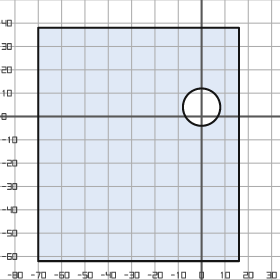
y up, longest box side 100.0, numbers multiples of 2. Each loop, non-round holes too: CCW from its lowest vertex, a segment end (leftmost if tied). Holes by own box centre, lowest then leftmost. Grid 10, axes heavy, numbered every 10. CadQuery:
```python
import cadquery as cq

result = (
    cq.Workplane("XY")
    .moveTo(-70.0, -62.0)
    .lineTo(16.0, -62.0)
    .lineTo(16.0, 38.0)
    .lineTo(-70.0, 38.0)
    .close()
    .moveTo(0.0, 4.0)
    .circle(8.0)
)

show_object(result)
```